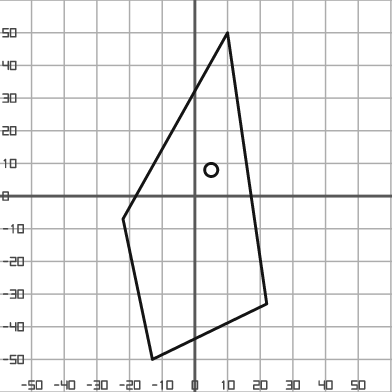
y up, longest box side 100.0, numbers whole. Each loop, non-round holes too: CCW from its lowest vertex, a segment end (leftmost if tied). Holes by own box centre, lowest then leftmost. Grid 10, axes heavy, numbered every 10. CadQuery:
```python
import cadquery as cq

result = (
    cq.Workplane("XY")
    .moveTo(-13.0, -50.0)
    .lineTo(22.0, -33.0)
    .lineTo(10.0, 50.0)
    .lineTo(-22.0, -7.0)
    .close()
    .moveTo(5.0, 8.0)
    .circle(2.0)
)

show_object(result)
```